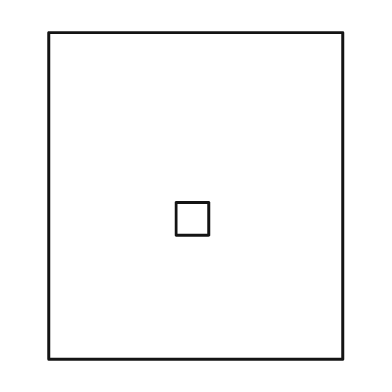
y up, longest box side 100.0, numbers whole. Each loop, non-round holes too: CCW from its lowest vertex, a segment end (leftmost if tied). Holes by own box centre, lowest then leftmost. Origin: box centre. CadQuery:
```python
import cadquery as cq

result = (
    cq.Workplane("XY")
    .moveTo(-45.0, -50.0)
    .lineTo(45.0, -50.0)
    .lineTo(45.0, 50.0)
    .lineTo(-45.0, 50.0)
    .close()
    .moveTo(-6.0, -12.0)
    .lineTo(4.0, -12.0)
    .lineTo(4.0, -2.0)
    .lineTo(-6.0, -2.0)
    .close()
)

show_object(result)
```